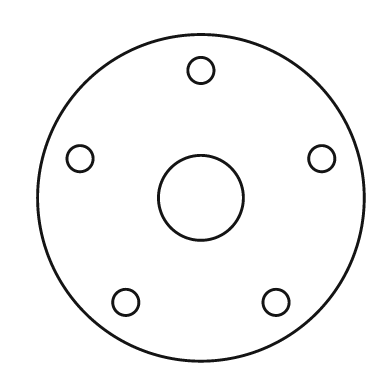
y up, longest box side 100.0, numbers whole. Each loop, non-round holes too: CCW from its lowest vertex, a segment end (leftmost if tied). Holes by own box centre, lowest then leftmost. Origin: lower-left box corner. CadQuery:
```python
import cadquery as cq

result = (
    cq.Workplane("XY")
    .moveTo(50.0, 50.0)
    .circle(50.0)
    .moveTo(27.0, 18.0)
    .circle(4.0)
    .moveTo(73.0, 18.0)
    .circle(4.0)
    .moveTo(50.0, 50.0)
    .circle(13.0)
    .moveTo(13.0, 62.0)
    .circle(4.0)
    .moveTo(87.0, 62.0)
    .circle(4.0)
    .moveTo(50.0, 89.0)
    .circle(4.0)
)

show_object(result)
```